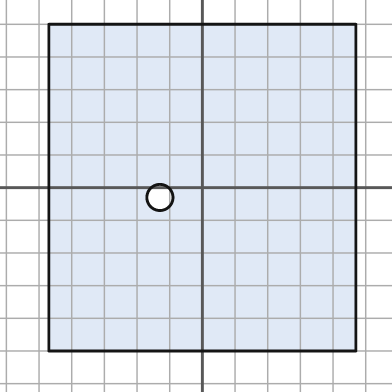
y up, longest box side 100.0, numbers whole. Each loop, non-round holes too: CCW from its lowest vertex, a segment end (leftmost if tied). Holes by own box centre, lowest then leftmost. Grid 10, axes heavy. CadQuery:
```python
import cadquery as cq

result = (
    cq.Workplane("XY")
    .moveTo(-47.0, -50.0)
    .lineTo(47.0, -50.0)
    .lineTo(47.0, 50.0)
    .lineTo(-47.0, 50.0)
    .close()
    .moveTo(-13.0, -3.0)
    .circle(4.0)
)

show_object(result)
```